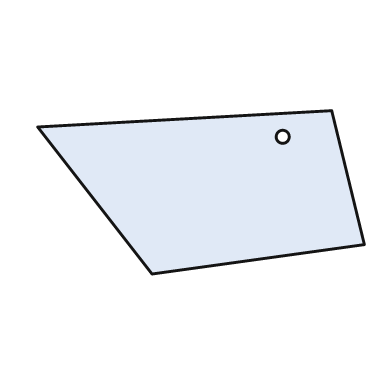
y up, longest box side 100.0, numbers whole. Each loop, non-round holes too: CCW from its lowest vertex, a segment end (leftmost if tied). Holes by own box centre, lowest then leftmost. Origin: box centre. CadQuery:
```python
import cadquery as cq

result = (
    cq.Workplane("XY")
    .moveTo(-15.0, -25.0)
    .lineTo(50.0, -16.0)
    .lineTo(40.0, 25.0)
    .lineTo(-50.0, 20.0)
    .close()
    .moveTo(25.0, 17.0)
    .circle(2.0)
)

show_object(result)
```